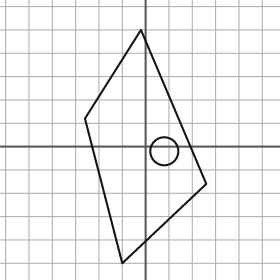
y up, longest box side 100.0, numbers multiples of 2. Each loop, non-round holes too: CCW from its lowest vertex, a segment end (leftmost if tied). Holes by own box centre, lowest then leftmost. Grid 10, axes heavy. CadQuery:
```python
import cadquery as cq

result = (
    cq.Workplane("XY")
    .moveTo(-10.0, -50.0)
    .lineTo(26.0, -16.0)
    .lineTo(-2.0, 50.0)
    .lineTo(-26.0, 12.0)
    .close()
    .moveTo(8.0, -2.0)
    .circle(6.0)
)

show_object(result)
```